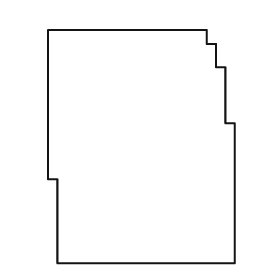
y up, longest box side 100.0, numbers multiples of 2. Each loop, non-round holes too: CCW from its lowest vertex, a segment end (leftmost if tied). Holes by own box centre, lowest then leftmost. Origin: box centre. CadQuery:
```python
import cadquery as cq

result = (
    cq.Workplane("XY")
    .moveTo(-36.0, -50.0)
    .lineTo(40.0, -50.0)
    .lineTo(40.0, 10.0)
    .lineTo(36.0, 10.0)
    .lineTo(36.0, 34.0)
    .lineTo(32.0, 34.0)
    .lineTo(32.0, 44.0)
    .lineTo(28.0, 44.0)
    .lineTo(28.0, 50.0)
    .lineTo(-40.0, 50.0)
    .lineTo(-40.0, -14.0)
    .lineTo(-36.0, -14.0)
    .close()
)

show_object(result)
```